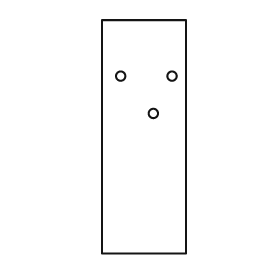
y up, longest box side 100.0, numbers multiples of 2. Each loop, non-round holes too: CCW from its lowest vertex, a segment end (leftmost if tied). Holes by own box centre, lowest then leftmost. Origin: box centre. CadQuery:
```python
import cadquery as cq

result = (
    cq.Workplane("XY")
    .moveTo(-18.0, -50.0)
    .lineTo(18.0, -50.0)
    .lineTo(18.0, 50.0)
    .lineTo(-18.0, 50.0)
    .close()
    .moveTo(4.0, 10.0)
    .circle(2.0)
    .moveTo(-10.0, 26.0)
    .circle(2.0)
    .moveTo(12.0, 26.0)
    .circle(2.0)
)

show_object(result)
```